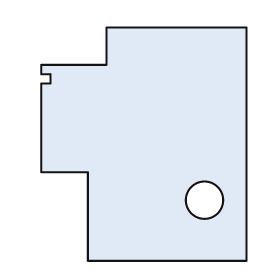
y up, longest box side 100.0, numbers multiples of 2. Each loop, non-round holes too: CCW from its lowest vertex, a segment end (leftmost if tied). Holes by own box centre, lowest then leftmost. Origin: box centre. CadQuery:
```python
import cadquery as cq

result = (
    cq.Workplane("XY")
    .moveTo(-24.0, -50.0)
    .lineTo(44.0, -50.0)
    .lineTo(44.0, 50.0)
    .lineTo(-16.0, 50.0)
    .lineTo(-16.0, 34.0)
    .lineTo(-44.0, 34.0)
    .lineTo(-44.0, 30.0)
    .lineTo(-40.0, 30.0)
    .lineTo(-40.0, 26.0)
    .lineTo(-44.0, 26.0)
    .lineTo(-44.0, -12.0)
    .lineTo(-24.0, -12.0)
    .close()
    .moveTo(26.0, -24.0)
    .circle(8.0)
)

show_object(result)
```